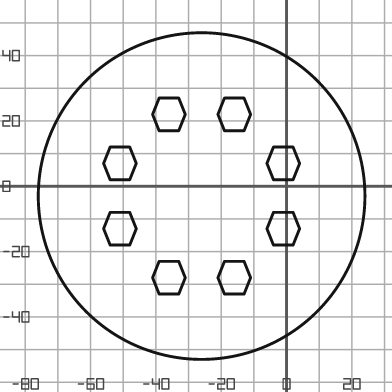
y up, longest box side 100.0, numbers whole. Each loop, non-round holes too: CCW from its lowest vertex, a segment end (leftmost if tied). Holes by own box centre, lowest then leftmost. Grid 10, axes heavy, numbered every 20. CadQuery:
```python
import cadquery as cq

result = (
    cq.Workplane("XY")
    .moveTo(-26.0, -3.0)
    .circle(50.0)
    .moveTo(-39.0, -33.0)
    .lineTo(-33.0, -33.0)
    .lineTo(-31.0, -28.0)
    .lineTo(-33.0, -23.0)
    .lineTo(-39.0, -23.0)
    .lineTo(-41.0, -28.0)
    .close()
    .moveTo(-19.0, -33.0)
    .lineTo(-13.0, -33.0)
    .lineTo(-11.0, -28.0)
    .lineTo(-13.0, -23.0)
    .lineTo(-19.0, -23.0)
    .lineTo(-21.0, -28.0)
    .close()
    .moveTo(-54.0, -18.0)
    .lineTo(-48.0, -18.0)
    .lineTo(-46.0, -13.0)
    .lineTo(-48.0, -8.0)
    .lineTo(-54.0, -8.0)
    .lineTo(-56.0, -13.0)
    .close()
    .moveTo(-4.0, -18.0)
    .lineTo(2.0, -18.0)
    .lineTo(4.0, -13.0)
    .lineTo(2.0, -8.0)
    .lineTo(-4.0, -8.0)
    .lineTo(-6.0, -13.0)
    .close()
    .moveTo(-54.0, 2.0)
    .lineTo(-48.0, 2.0)
    .lineTo(-46.0, 7.0)
    .lineTo(-48.0, 12.0)
    .lineTo(-54.0, 12.0)
    .lineTo(-56.0, 7.0)
    .close()
    .moveTo(-4.0, 2.0)
    .lineTo(2.0, 2.0)
    .lineTo(4.0, 7.0)
    .lineTo(2.0, 12.0)
    .lineTo(-4.0, 12.0)
    .lineTo(-6.0, 7.0)
    .close()
    .moveTo(-39.0, 17.0)
    .lineTo(-33.0, 17.0)
    .lineTo(-31.0, 22.0)
    .lineTo(-33.0, 27.0)
    .lineTo(-39.0, 27.0)
    .lineTo(-41.0, 22.0)
    .close()
    .moveTo(-19.0, 17.0)
    .lineTo(-13.0, 17.0)
    .lineTo(-11.0, 22.0)
    .lineTo(-13.0, 27.0)
    .lineTo(-19.0, 27.0)
    .lineTo(-21.0, 22.0)
    .close()
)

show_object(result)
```